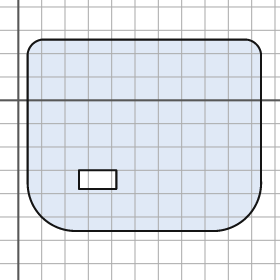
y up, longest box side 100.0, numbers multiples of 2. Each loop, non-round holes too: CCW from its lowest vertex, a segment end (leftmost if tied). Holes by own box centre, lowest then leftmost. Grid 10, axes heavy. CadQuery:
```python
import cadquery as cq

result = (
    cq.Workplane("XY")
    .moveTo(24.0, -56.0)
    .lineTo(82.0, -56.0)
    .threePointArc((98.0, -50.0), (104.0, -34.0))
    .lineTo(104.0, 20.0)
    .threePointArc((102.0, 24.0), (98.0, 26.0))
    .lineTo(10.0, 26.0)
    .threePointArc((6.0, 24.0), (4.0, 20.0))
    .lineTo(4.0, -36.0)
    .threePointArc((10.0, -50.0), (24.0, -56.0))
    .close()
    .moveTo(26.0, -38.0)
    .lineTo(42.0, -38.0)
    .lineTo(42.0, -30.0)
    .lineTo(26.0, -30.0)
    .close()
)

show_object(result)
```